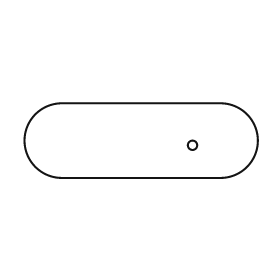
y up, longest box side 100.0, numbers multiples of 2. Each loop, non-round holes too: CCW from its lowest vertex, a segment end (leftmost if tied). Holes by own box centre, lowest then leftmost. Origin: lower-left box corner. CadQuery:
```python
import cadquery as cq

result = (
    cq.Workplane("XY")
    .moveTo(16.0, 0.0)
    .lineTo(84.0, 0.0)
    .threePointArc((100.0, 16.0), (84.0, 32.0))
    .lineTo(16.0, 32.0)
    .threePointArc((0.0, 16.0), (16.0, 0.0))
    .close()
    .moveTo(72.0, 14.0)
    .circle(2.0)
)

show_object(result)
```